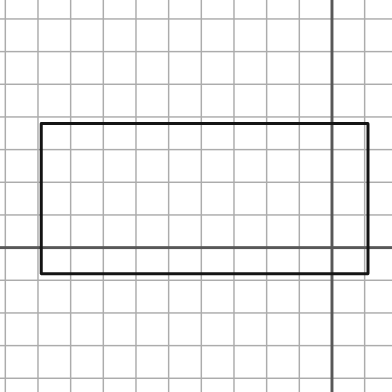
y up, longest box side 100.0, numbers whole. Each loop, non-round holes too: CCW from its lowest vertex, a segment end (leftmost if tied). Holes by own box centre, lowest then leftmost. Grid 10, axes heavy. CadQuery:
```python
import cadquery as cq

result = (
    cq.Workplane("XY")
    .moveTo(-89.0, -8.0)
    .lineTo(11.0, -8.0)
    .lineTo(11.0, 38.0)
    .lineTo(-89.0, 38.0)
    .close()
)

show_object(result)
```